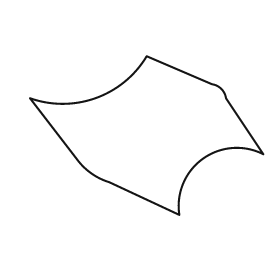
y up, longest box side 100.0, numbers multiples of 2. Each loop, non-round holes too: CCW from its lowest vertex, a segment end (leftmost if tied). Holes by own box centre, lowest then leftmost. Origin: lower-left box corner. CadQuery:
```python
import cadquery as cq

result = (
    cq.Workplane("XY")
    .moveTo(64.0, 0.0)
    .threePointArc((74.0, 24.0), (100.0, 26.0))
    .lineTo(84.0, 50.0)
    .threePointArc((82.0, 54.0), (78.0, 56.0))
    .lineTo(50.0, 68.0)
    .threePointArc((28.0, 50.0), (0.0, 50.0))
    .lineTo(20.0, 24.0)
    .threePointArc((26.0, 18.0), (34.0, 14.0))
    .close()
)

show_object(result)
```